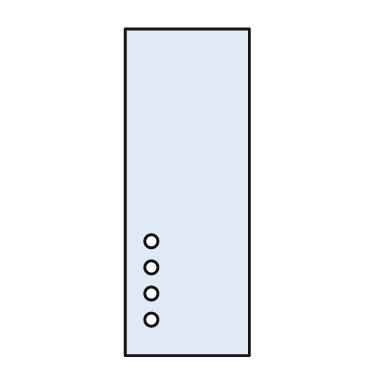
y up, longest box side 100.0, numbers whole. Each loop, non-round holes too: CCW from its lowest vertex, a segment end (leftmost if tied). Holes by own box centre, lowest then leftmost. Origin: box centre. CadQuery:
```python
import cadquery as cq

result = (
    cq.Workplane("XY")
    .moveTo(-19.0, -50.0)
    .lineTo(19.0, -50.0)
    .lineTo(19.0, 50.0)
    .lineTo(-19.0, 50.0)
    .close()
    .moveTo(-11.0, -39.0)
    .circle(2.0)
    .moveTo(-11.0, -31.0)
    .circle(2.0)
    .moveTo(-11.0, -23.0)
    .circle(2.0)
    .moveTo(-11.0, -15.0)
    .circle(2.0)
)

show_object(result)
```